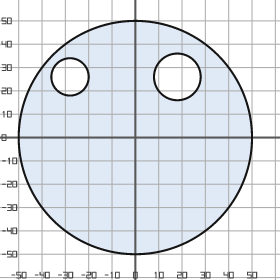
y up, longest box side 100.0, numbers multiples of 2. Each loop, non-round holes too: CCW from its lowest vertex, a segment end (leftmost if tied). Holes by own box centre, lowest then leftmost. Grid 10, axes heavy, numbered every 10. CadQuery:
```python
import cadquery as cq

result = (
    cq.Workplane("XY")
    .moveTo(0.0, 0.0)
    .circle(50.0)
    .moveTo(-28.0, 26.0)
    .circle(8.0)
    .moveTo(18.0, 26.0)
    .circle(10.0)
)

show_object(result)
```